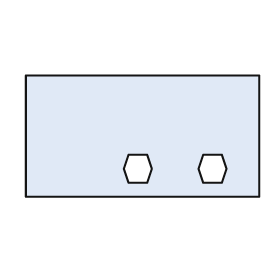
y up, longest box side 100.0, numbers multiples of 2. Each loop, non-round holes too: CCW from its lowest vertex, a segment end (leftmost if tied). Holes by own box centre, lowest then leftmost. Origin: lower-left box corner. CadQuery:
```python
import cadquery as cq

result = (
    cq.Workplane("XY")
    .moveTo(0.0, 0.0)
    .lineTo(100.0, 0.0)
    .lineTo(100.0, 52.0)
    .lineTo(0.0, 52.0)
    .close()
    .moveTo(44.0, 6.0)
    .lineTo(52.0, 6.0)
    .lineTo(54.0, 12.0)
    .lineTo(52.0, 18.0)
    .lineTo(44.0, 18.0)
    .lineTo(42.0, 12.0)
    .close()
    .moveTo(76.0, 6.0)
    .lineTo(84.0, 6.0)
    .lineTo(86.0, 12.0)
    .lineTo(84.0, 18.0)
    .lineTo(76.0, 18.0)
    .lineTo(74.0, 12.0)
    .close()
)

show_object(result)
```